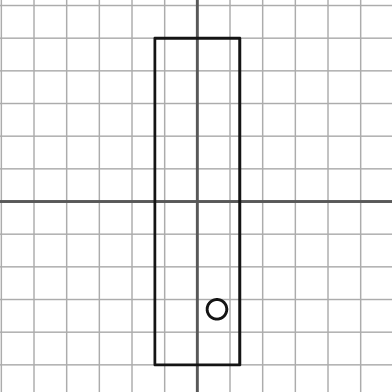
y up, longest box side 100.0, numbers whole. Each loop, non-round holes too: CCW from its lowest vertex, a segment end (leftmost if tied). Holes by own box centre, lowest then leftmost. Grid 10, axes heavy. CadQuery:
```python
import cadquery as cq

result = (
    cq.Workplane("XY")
    .moveTo(-13.0, -50.0)
    .lineTo(13.0, -50.0)
    .lineTo(13.0, 50.0)
    .lineTo(-13.0, 50.0)
    .close()
    .moveTo(6.0, -33.0)
    .circle(3.0)
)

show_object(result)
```